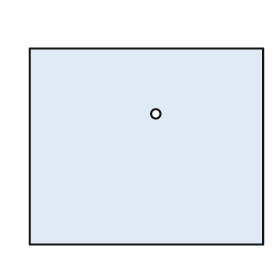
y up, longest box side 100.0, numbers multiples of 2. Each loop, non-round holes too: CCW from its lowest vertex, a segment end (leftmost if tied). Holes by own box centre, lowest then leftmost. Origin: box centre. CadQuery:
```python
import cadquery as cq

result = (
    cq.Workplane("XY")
    .moveTo(-50.0, -42.0)
    .lineTo(50.0, -42.0)
    .lineTo(50.0, 42.0)
    .lineTo(-50.0, 42.0)
    .close()
    .moveTo(4.0, 14.0)
    .circle(2.0)
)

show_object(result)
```